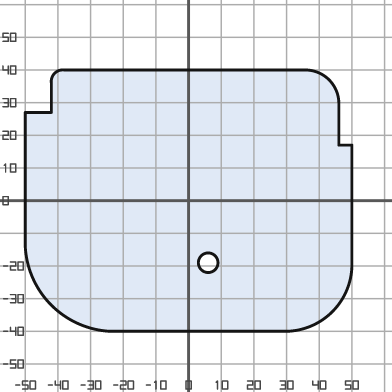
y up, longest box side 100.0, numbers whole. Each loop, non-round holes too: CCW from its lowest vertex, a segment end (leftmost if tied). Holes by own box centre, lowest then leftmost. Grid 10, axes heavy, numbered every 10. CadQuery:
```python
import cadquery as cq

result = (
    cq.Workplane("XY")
    .moveTo(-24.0, -40.0)
    .lineTo(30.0, -40.0)
    .threePointArc((44.0, -34.0), (50.0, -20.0))
    .lineTo(50.0, 17.0)
    .lineTo(46.0, 17.0)
    .lineTo(46.0, 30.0)
    .threePointArc((43.0, 37.0), (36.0, 40.0))
    .lineTo(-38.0, 40.0)
    .threePointArc((-41.0, 39.0), (-42.0, 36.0))
    .lineTo(-42.0, 27.0)
    .lineTo(-50.0, 27.0)
    .lineTo(-50.0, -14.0)
    .threePointArc((-42.0, -32.0), (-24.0, -40.0))
    .close()
    .moveTo(6.0, -19.0)
    .circle(3.0)
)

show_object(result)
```